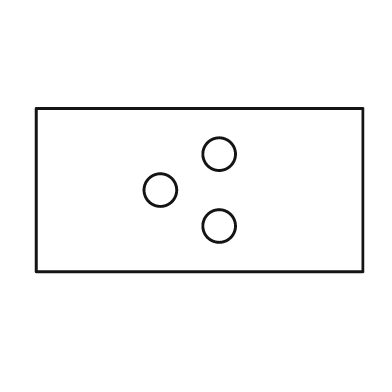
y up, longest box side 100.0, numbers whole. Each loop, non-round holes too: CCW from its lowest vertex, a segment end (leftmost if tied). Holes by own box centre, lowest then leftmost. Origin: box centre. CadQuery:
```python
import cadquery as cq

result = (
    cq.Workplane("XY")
    .moveTo(-50.0, -25.0)
    .lineTo(50.0, -25.0)
    .lineTo(50.0, 25.0)
    .lineTo(-50.0, 25.0)
    .close()
    .moveTo(6.0, -11.0)
    .circle(5.0)
    .moveTo(-12.0, 0.0)
    .circle(5.0)
    .moveTo(6.0, 11.0)
    .circle(5.0)
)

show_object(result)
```